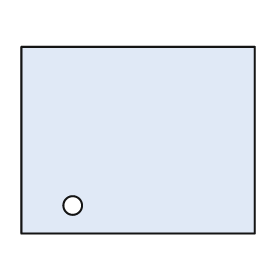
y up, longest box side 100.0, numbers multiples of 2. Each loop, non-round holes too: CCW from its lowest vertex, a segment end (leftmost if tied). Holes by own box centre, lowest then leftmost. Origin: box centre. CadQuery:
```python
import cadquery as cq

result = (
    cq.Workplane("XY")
    .moveTo(-50.0, -40.0)
    .lineTo(50.0, -40.0)
    .lineTo(50.0, 40.0)
    .lineTo(-50.0, 40.0)
    .close()
    .moveTo(-28.0, -28.0)
    .circle(4.0)
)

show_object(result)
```